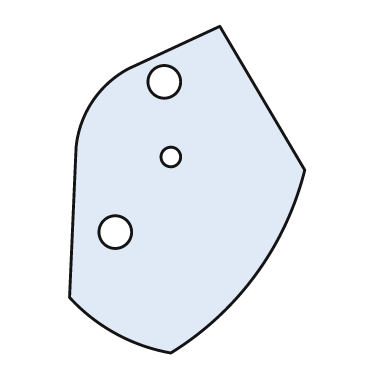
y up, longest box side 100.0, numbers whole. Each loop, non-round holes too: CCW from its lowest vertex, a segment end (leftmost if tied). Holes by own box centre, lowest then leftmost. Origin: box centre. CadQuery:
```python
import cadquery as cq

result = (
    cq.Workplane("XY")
    .moveTo(-5.0, -50.0)
    .threePointArc((21.0, -26.0), (36.0, 6.0))
    .lineTo(10.0, 50.0)
    .lineTo(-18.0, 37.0)
    .threePointArc((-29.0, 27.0), (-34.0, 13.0))
    .lineTo(-36.0, -33.0)
    .threePointArc((-22.0, -44.0), (-5.0, -50.0))
    .close()
    .moveTo(-22.0, -13.0)
    .circle(5.0)
    .moveTo(-5.0, 10.0)
    .circle(3.0)
    .moveTo(-7.0, 33.0)
    .circle(5.0)
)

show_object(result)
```